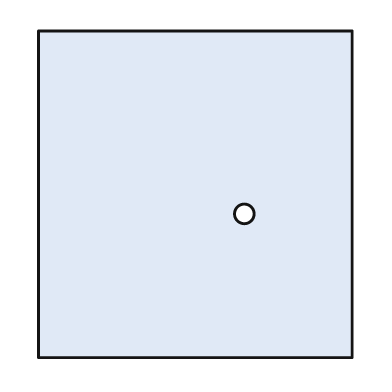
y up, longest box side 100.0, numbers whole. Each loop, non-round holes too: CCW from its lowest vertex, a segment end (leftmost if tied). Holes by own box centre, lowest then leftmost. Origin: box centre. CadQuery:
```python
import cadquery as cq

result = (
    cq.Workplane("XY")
    .moveTo(-48.0, -50.0)
    .lineTo(48.0, -50.0)
    .lineTo(48.0, 50.0)
    .lineTo(-48.0, 50.0)
    .close()
    .moveTo(15.0, -6.0)
    .circle(3.0)
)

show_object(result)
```